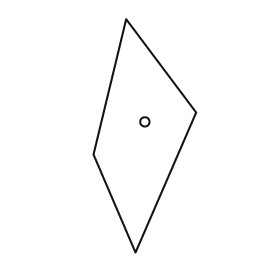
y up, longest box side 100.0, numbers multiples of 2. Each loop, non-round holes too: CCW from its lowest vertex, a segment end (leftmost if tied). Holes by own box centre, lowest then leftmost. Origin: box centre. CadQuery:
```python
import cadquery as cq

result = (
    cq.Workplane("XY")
    .moveTo(-4.0, -50.0)
    .lineTo(22.0, 10.0)
    .lineTo(-8.0, 50.0)
    .lineTo(-22.0, -8.0)
    .close()
    .moveTo(0.0, 6.0)
    .circle(2.0)
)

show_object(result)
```